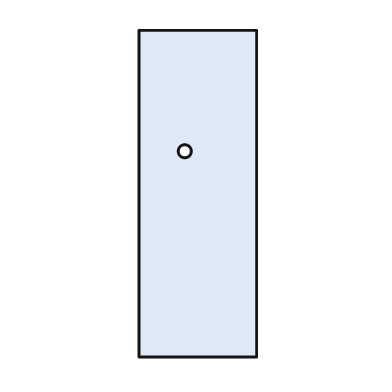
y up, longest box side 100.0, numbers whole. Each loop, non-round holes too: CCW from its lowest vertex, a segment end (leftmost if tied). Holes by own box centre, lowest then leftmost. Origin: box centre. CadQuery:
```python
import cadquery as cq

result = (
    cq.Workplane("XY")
    .moveTo(-18.0, -50.0)
    .lineTo(18.0, -50.0)
    .lineTo(18.0, 50.0)
    .lineTo(-18.0, 50.0)
    .close()
    .moveTo(-4.0, 13.0)
    .circle(2.0)
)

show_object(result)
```